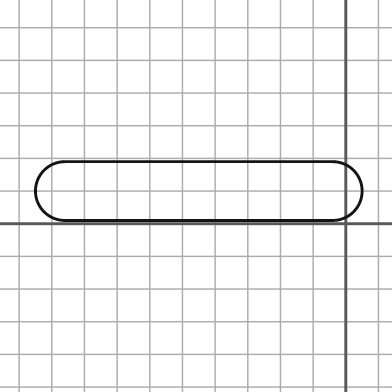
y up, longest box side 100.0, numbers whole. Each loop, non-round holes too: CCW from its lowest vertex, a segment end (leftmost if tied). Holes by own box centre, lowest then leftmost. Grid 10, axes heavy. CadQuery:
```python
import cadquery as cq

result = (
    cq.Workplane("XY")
    .moveTo(-86.0, 1.0)
    .lineTo(-4.0, 1.0)
    .threePointArc((5.0, 10.0), (-4.0, 19.0))
    .lineTo(-86.0, 19.0)
    .threePointArc((-95.0, 10.0), (-86.0, 1.0))
    .close()
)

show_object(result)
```